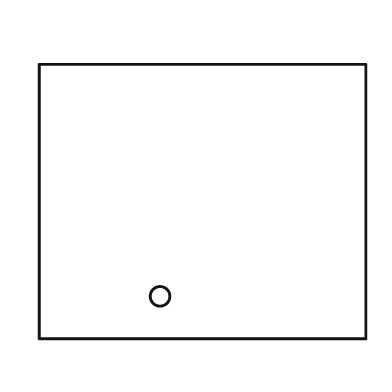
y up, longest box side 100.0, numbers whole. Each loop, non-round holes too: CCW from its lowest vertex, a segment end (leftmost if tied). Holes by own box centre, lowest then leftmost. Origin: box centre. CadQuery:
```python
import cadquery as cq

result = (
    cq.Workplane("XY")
    .moveTo(-50.0, -42.0)
    .lineTo(50.0, -42.0)
    .lineTo(50.0, 42.0)
    .lineTo(-50.0, 42.0)
    .close()
    .moveTo(-13.0, -29.0)
    .circle(3.0)
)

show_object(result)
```